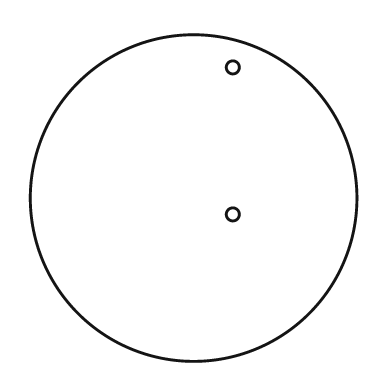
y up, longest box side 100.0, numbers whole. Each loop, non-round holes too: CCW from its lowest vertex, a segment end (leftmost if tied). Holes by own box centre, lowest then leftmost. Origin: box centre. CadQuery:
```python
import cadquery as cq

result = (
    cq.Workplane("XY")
    .moveTo(0.0, 0.0)
    .circle(50.0)
    .moveTo(12.0, -5.0)
    .circle(2.0)
    .moveTo(12.0, 40.0)
    .circle(2.0)
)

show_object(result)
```